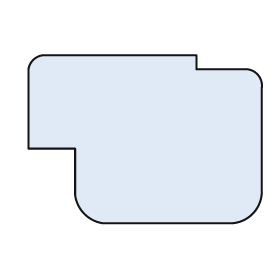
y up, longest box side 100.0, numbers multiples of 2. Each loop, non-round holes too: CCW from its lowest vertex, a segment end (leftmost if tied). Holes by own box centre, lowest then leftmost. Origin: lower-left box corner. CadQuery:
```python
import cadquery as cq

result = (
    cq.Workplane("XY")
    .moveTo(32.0, 0.0)
    .lineTo(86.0, 0.0)
    .threePointArc((96.0, 4.0), (100.0, 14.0))
    .lineTo(100.0, 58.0)
    .threePointArc((98.0, 64.0), (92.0, 66.0))
    .lineTo(72.0, 66.0)
    .lineTo(72.0, 72.0)
    .lineTo(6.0, 72.0)
    .threePointArc((2.0, 70.0), (0.0, 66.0))
    .lineTo(0.0, 32.0)
    .lineTo(20.0, 32.0)
    .lineTo(20.0, 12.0)
    .threePointArc((24.0, 4.0), (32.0, 0.0))
    .close()
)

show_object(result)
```